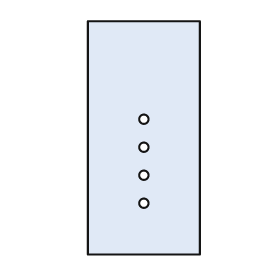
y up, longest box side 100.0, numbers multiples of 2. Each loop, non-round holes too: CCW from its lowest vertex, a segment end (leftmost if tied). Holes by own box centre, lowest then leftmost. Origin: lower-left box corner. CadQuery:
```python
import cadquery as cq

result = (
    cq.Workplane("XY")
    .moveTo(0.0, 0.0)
    .lineTo(48.0, 0.0)
    .lineTo(48.0, 100.0)
    .lineTo(0.0, 100.0)
    .close()
    .moveTo(24.0, 22.0)
    .circle(2.0)
    .moveTo(24.0, 34.0)
    .circle(2.0)
    .moveTo(24.0, 46.0)
    .circle(2.0)
    .moveTo(24.0, 58.0)
    .circle(2.0)
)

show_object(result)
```